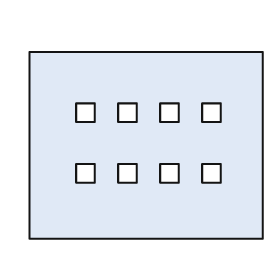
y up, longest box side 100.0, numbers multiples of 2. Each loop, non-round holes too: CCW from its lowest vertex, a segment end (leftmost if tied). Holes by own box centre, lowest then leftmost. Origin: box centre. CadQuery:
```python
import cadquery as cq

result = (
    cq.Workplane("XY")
    .moveTo(-50.0, -40.0)
    .lineTo(50.0, -40.0)
    .lineTo(50.0, 40.0)
    .lineTo(-50.0, 40.0)
    .close()
    .moveTo(-30.0, -16.0)
    .lineTo(-22.0, -16.0)
    .lineTo(-22.0, -8.0)
    .lineTo(-30.0, -8.0)
    .close()
    .moveTo(-12.0, -16.0)
    .lineTo(-4.0, -16.0)
    .lineTo(-4.0, -8.0)
    .lineTo(-12.0, -8.0)
    .close()
    .moveTo(6.0, -16.0)
    .lineTo(14.0, -16.0)
    .lineTo(14.0, -8.0)
    .lineTo(6.0, -8.0)
    .close()
    .moveTo(24.0, -16.0)
    .lineTo(32.0, -16.0)
    .lineTo(32.0, -8.0)
    .lineTo(24.0, -8.0)
    .close()
    .moveTo(-30.0, 10.0)
    .lineTo(-22.0, 10.0)
    .lineTo(-22.0, 18.0)
    .lineTo(-30.0, 18.0)
    .close()
    .moveTo(-12.0, 10.0)
    .lineTo(-4.0, 10.0)
    .lineTo(-4.0, 18.0)
    .lineTo(-12.0, 18.0)
    .close()
    .moveTo(6.0, 10.0)
    .lineTo(14.0, 10.0)
    .lineTo(14.0, 18.0)
    .lineTo(6.0, 18.0)
    .close()
    .moveTo(24.0, 10.0)
    .lineTo(32.0, 10.0)
    .lineTo(32.0, 18.0)
    .lineTo(24.0, 18.0)
    .close()
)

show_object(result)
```